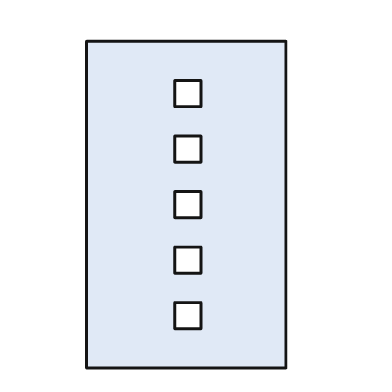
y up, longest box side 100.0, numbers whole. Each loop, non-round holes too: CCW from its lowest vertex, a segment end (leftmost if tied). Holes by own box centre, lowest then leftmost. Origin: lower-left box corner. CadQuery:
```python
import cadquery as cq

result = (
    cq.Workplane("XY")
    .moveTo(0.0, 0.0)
    .lineTo(61.0, 0.0)
    .lineTo(61.0, 100.0)
    .lineTo(0.0, 100.0)
    .close()
    .moveTo(27.0, 12.0)
    .lineTo(35.0, 12.0)
    .lineTo(35.0, 20.0)
    .lineTo(27.0, 20.0)
    .close()
    .moveTo(27.0, 29.0)
    .lineTo(35.0, 29.0)
    .lineTo(35.0, 37.0)
    .lineTo(27.0, 37.0)
    .close()
    .moveTo(27.0, 46.0)
    .lineTo(35.0, 46.0)
    .lineTo(35.0, 54.0)
    .lineTo(27.0, 54.0)
    .close()
    .moveTo(27.0, 63.0)
    .lineTo(35.0, 63.0)
    .lineTo(35.0, 71.0)
    .lineTo(27.0, 71.0)
    .close()
    .moveTo(27.0, 80.0)
    .lineTo(35.0, 80.0)
    .lineTo(35.0, 88.0)
    .lineTo(27.0, 88.0)
    .close()
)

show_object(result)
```